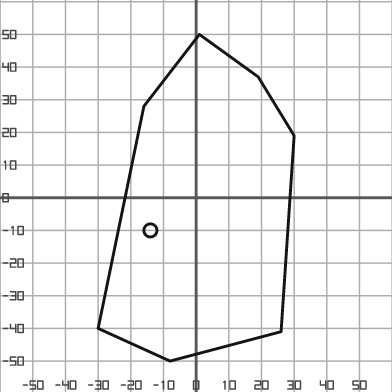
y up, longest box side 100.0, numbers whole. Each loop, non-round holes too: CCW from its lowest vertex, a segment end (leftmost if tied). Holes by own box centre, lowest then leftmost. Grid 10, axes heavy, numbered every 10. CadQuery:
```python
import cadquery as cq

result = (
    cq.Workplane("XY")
    .moveTo(-8.0, -50.0)
    .lineTo(26.0, -41.0)
    .lineTo(30.0, 19.0)
    .lineTo(19.0, 37.0)
    .lineTo(1.0, 50.0)
    .lineTo(-16.0, 28.0)
    .lineTo(-30.0, -40.0)
    .close()
    .moveTo(-14.0, -10.0)
    .circle(2.0)
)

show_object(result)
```